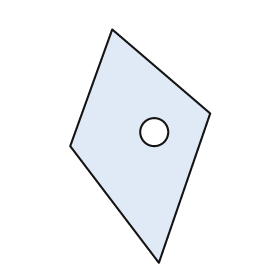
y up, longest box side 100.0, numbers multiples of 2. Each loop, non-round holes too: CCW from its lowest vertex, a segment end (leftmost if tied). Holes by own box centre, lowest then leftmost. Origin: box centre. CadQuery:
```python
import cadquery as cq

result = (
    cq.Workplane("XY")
    .moveTo(8.0, -50.0)
    .lineTo(30.0, 14.0)
    .lineTo(-12.0, 50.0)
    .lineTo(-30.0, 0.0)
    .close()
    .moveTo(6.0, 6.0)
    .circle(6.0)
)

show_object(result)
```